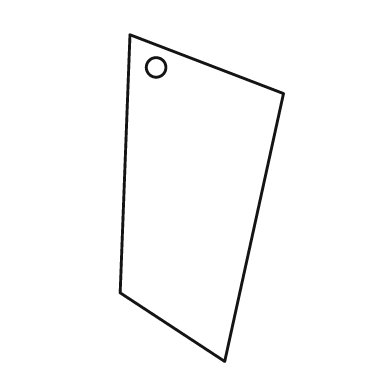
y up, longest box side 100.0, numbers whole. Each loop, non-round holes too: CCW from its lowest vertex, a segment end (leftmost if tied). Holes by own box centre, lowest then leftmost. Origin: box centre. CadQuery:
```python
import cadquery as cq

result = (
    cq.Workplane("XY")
    .moveTo(7.0, -50.0)
    .lineTo(25.0, 32.0)
    .lineTo(-22.0, 50.0)
    .lineTo(-25.0, -29.0)
    .close()
    .moveTo(-14.0, 40.0)
    .circle(3.0)
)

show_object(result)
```